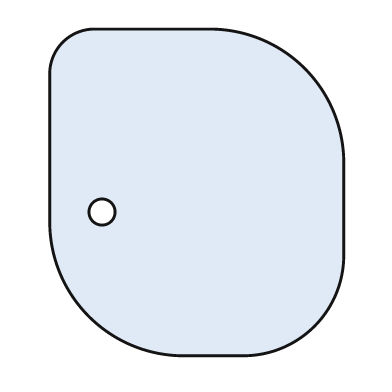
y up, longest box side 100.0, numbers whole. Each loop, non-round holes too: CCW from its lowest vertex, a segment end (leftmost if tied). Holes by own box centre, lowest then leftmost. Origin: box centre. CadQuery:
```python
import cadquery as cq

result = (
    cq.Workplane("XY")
    .moveTo(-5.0, -50.0)
    .lineTo(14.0, -50.0)
    .threePointArc((36.0, -41.0), (45.0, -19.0))
    .lineTo(45.0, 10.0)
    .threePointArc((33.0, 38.0), (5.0, 50.0))
    .lineTo(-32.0, 50.0)
    .threePointArc((-41.0, 46.0), (-45.0, 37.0))
    .lineTo(-45.0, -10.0)
    .threePointArc((-33.0, -38.0), (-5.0, -50.0))
    .close()
    .moveTo(-29.0, -6.0)
    .circle(4.0)
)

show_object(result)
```